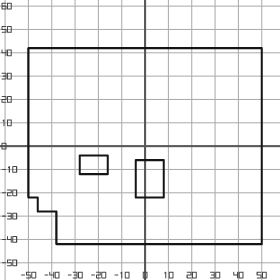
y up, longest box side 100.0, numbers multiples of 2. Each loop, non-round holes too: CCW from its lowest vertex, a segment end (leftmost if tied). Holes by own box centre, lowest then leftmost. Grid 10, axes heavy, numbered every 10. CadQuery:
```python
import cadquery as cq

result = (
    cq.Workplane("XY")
    .moveTo(-38.0, -42.0)
    .lineTo(50.0, -42.0)
    .lineTo(50.0, 42.0)
    .lineTo(-50.0, 42.0)
    .lineTo(-50.0, -22.0)
    .lineTo(-46.0, -22.0)
    .lineTo(-46.0, -28.0)
    .lineTo(-38.0, -28.0)
    .close()
    .moveTo(-4.0, -22.0)
    .lineTo(8.0, -22.0)
    .lineTo(8.0, -6.0)
    .lineTo(-4.0, -6.0)
    .close()
    .moveTo(-28.0, -12.0)
    .lineTo(-16.0, -12.0)
    .lineTo(-16.0, -4.0)
    .lineTo(-28.0, -4.0)
    .close()
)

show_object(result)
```